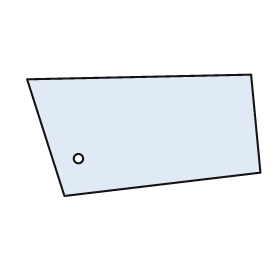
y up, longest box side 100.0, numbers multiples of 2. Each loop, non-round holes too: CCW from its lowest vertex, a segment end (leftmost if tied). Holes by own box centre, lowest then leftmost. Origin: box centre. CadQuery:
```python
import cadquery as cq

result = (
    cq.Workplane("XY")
    .moveTo(-34.0, -26.0)
    .lineTo(50.0, -16.0)
    .lineTo(46.0, 26.0)
    .lineTo(-50.0, 24.0)
    .close()
    .moveTo(-28.0, -10.0)
    .circle(2.0)
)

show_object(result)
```